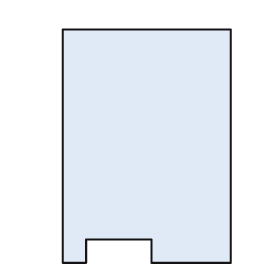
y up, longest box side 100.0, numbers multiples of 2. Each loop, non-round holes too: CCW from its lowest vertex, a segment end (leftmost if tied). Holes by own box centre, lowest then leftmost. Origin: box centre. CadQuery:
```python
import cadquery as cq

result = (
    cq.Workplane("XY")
    .moveTo(-36.0, -50.0)
    .lineTo(-26.0, -50.0)
    .lineTo(-26.0, -40.0)
    .lineTo(2.0, -40.0)
    .lineTo(2.0, -50.0)
    .lineTo(36.0, -50.0)
    .lineTo(36.0, 50.0)
    .lineTo(-36.0, 50.0)
    .close()
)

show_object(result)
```